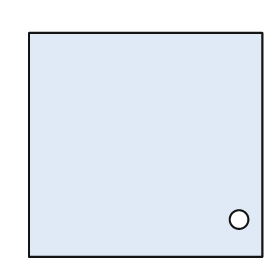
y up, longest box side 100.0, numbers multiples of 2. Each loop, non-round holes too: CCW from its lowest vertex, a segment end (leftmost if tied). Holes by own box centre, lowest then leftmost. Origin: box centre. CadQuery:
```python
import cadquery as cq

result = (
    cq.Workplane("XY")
    .moveTo(-50.0, -48.0)
    .lineTo(50.0, -48.0)
    .lineTo(50.0, 48.0)
    .lineTo(-50.0, 48.0)
    .close()
    .moveTo(40.0, -32.0)
    .circle(4.0)
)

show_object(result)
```